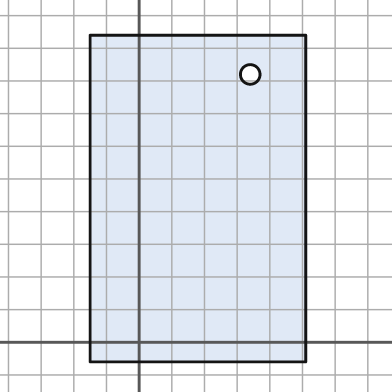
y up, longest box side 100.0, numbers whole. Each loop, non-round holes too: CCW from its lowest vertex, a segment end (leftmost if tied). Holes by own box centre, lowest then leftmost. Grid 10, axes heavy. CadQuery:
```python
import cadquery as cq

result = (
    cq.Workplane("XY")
    .moveTo(-15.0, -6.0)
    .lineTo(51.0, -6.0)
    .lineTo(51.0, 94.0)
    .lineTo(-15.0, 94.0)
    .close()
    .moveTo(34.0, 82.0)
    .circle(3.0)
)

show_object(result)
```